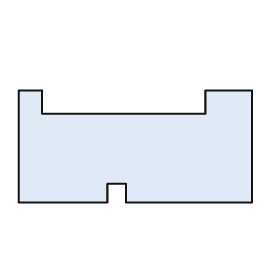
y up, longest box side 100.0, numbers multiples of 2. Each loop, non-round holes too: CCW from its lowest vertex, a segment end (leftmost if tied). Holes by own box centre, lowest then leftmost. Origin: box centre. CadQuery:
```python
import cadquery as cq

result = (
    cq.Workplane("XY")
    .moveTo(-50.0, -24.0)
    .lineTo(-12.0, -24.0)
    .lineTo(-12.0, -16.0)
    .lineTo(-4.0, -16.0)
    .lineTo(-4.0, -24.0)
    .lineTo(50.0, -24.0)
    .lineTo(50.0, 24.0)
    .lineTo(30.0, 24.0)
    .lineTo(30.0, 14.0)
    .lineTo(-40.0, 14.0)
    .lineTo(-40.0, 24.0)
    .lineTo(-50.0, 24.0)
    .close()
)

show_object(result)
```